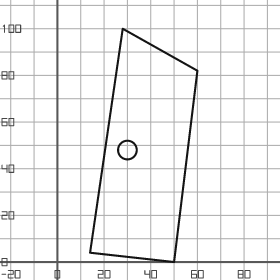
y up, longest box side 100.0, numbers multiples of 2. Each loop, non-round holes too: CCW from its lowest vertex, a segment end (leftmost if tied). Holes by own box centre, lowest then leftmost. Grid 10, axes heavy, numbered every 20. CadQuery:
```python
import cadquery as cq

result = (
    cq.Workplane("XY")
    .moveTo(50.0, 0.0)
    .lineTo(60.0, 82.0)
    .lineTo(28.0, 100.0)
    .lineTo(14.0, 4.0)
    .close()
    .moveTo(30.0, 48.0)
    .circle(4.0)
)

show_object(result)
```